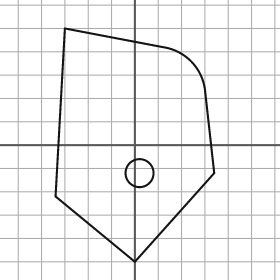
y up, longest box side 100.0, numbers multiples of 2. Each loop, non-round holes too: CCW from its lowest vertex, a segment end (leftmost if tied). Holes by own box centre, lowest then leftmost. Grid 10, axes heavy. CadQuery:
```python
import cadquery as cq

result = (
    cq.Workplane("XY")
    .moveTo(0.0, -50.0)
    .lineTo(34.0, -12.0)
    .lineTo(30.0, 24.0)
    .threePointArc((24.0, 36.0), (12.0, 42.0))
    .lineTo(-30.0, 50.0)
    .lineTo(-34.0, -22.0)
    .close()
    .moveTo(2.0, -12.0)
    .circle(6.0)
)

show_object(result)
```